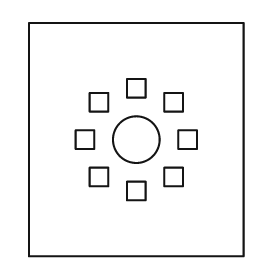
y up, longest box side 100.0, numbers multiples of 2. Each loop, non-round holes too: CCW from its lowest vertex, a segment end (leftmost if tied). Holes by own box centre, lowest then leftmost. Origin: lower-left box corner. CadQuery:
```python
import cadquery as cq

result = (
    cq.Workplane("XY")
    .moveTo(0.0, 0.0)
    .lineTo(92.0, 0.0)
    .lineTo(92.0, 100.0)
    .lineTo(0.0, 100.0)
    .close()
    .moveTo(42.0, 24.0)
    .lineTo(50.0, 24.0)
    .lineTo(50.0, 32.0)
    .lineTo(42.0, 32.0)
    .close()
    .moveTo(26.0, 30.0)
    .lineTo(34.0, 30.0)
    .lineTo(34.0, 38.0)
    .lineTo(26.0, 38.0)
    .close()
    .moveTo(58.0, 30.0)
    .lineTo(66.0, 30.0)
    .lineTo(66.0, 38.0)
    .lineTo(58.0, 38.0)
    .close()
    .moveTo(20.0, 46.0)
    .lineTo(28.0, 46.0)
    .lineTo(28.0, 54.0)
    .lineTo(20.0, 54.0)
    .close()
    .moveTo(46.0, 50.0)
    .circle(10.0)
    .moveTo(64.0, 46.0)
    .lineTo(72.0, 46.0)
    .lineTo(72.0, 54.0)
    .lineTo(64.0, 54.0)
    .close()
    .moveTo(26.0, 62.0)
    .lineTo(34.0, 62.0)
    .lineTo(34.0, 70.0)
    .lineTo(26.0, 70.0)
    .close()
    .moveTo(58.0, 62.0)
    .lineTo(66.0, 62.0)
    .lineTo(66.0, 70.0)
    .lineTo(58.0, 70.0)
    .close()
    .moveTo(42.0, 68.0)
    .lineTo(50.0, 68.0)
    .lineTo(50.0, 76.0)
    .lineTo(42.0, 76.0)
    .close()
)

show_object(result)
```